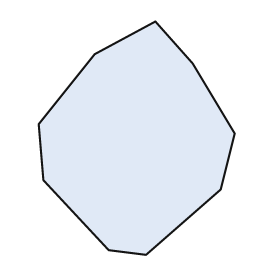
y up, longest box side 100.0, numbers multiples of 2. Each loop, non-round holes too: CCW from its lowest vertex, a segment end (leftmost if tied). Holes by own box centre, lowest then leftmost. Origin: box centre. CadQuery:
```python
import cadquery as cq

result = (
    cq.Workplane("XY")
    .moveTo(4.0, -50.0)
    .lineTo(36.0, -22.0)
    .lineTo(42.0, 2.0)
    .lineTo(24.0, 32.0)
    .lineTo(8.0, 50.0)
    .lineTo(-18.0, 36.0)
    .lineTo(-42.0, 6.0)
    .lineTo(-40.0, -18.0)
    .lineTo(-12.0, -48.0)
    .close()
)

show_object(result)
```